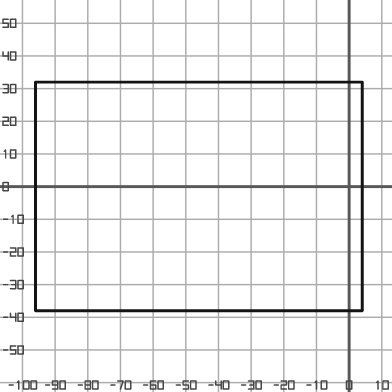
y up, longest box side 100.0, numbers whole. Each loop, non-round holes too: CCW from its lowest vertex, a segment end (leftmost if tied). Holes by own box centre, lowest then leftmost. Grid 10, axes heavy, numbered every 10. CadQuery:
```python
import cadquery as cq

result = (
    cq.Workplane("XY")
    .moveTo(-96.0, -38.0)
    .lineTo(4.0, -38.0)
    .lineTo(4.0, 32.0)
    .lineTo(-96.0, 32.0)
    .close()
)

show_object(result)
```